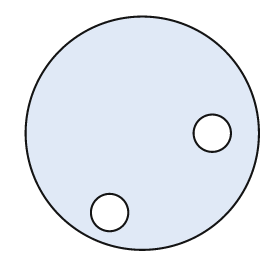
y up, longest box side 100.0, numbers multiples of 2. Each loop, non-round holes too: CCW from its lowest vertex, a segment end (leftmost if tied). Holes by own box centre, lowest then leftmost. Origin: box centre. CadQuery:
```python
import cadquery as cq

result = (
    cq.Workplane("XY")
    .moveTo(0.0, 0.0)
    .circle(50.0)
    .moveTo(-14.0, -34.0)
    .circle(8.0)
    .moveTo(30.0, 0.0)
    .circle(8.0)
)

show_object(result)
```